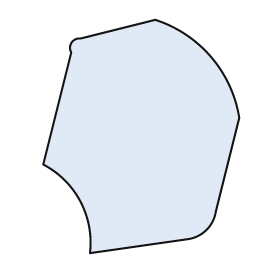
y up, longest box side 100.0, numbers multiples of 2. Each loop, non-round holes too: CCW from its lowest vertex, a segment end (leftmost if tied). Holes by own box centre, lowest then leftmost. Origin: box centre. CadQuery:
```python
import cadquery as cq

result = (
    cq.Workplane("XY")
    .moveTo(-22.0, -50.0)
    .lineTo(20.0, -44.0)
    .threePointArc((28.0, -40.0), (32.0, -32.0))
    .lineTo(42.0, 8.0)
    .threePointArc((30.0, 34.0), (6.0, 50.0))
    .lineTo(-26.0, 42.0)
    .threePointArc((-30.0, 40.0), (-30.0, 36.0))
    .lineTo(-42.0, -12.0)
    .threePointArc((-26.0, -28.0), (-22.0, -50.0))
    .close()
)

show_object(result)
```